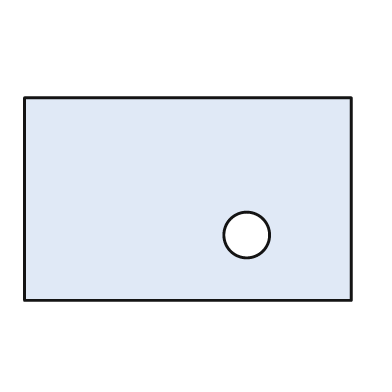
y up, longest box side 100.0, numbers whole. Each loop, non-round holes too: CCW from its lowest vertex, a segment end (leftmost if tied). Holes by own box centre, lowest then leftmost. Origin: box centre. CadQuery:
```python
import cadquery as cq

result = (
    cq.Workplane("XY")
    .moveTo(-50.0, -31.0)
    .lineTo(50.0, -31.0)
    .lineTo(50.0, 31.0)
    .lineTo(-50.0, 31.0)
    .close()
    .moveTo(18.0, -11.0)
    .circle(7.0)
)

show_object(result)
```